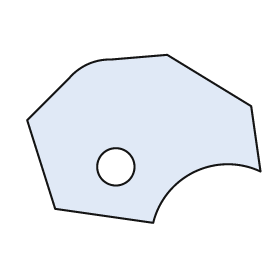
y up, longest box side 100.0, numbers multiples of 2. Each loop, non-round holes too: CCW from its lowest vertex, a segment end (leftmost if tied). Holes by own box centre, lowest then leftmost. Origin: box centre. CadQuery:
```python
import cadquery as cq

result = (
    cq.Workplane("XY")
    .moveTo(4.0, -36.0)
    .threePointArc((22.0, -14.0), (50.0, -14.0))
    .lineTo(46.0, 14.0)
    .lineTo(10.0, 36.0)
    .lineTo(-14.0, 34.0)
    .threePointArc((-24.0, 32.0), (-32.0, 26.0))
    .lineTo(-50.0, 8.0)
    .lineTo(-38.0, -30.0)
    .close()
    .moveTo(-12.0, -12.0)
    .circle(8.0)
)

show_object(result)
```